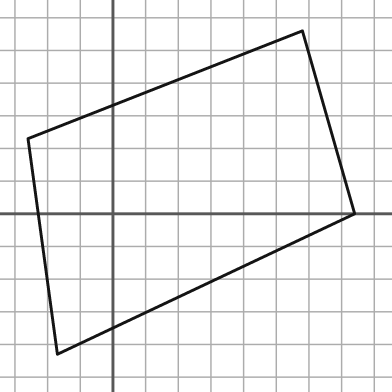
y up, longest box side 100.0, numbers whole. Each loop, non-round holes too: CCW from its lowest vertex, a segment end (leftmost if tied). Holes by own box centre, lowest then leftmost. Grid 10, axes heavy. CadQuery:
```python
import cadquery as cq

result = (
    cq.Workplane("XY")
    .moveTo(-17.0, -43.0)
    .lineTo(74.0, 0.0)
    .lineTo(58.0, 56.0)
    .lineTo(-26.0, 23.0)
    .close()
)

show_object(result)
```